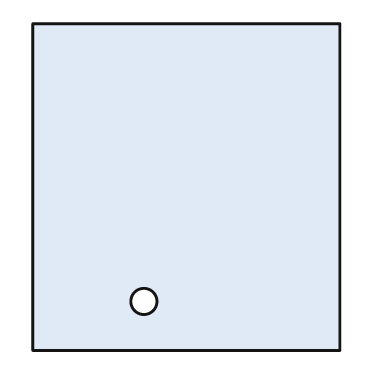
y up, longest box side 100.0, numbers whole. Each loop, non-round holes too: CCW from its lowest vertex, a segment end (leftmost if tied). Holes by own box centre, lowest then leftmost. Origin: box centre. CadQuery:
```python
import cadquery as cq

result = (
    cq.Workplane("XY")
    .moveTo(-47.0, -50.0)
    .lineTo(47.0, -50.0)
    .lineTo(47.0, 50.0)
    .lineTo(-47.0, 50.0)
    .close()
    .moveTo(-13.0, -35.0)
    .circle(4.0)
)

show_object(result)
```